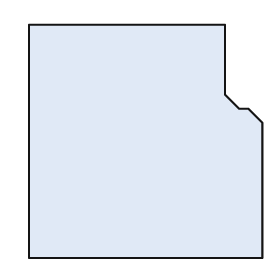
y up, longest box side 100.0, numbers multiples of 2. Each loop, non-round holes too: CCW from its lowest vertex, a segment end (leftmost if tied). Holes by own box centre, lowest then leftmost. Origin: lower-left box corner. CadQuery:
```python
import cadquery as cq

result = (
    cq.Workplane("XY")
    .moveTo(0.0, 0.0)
    .lineTo(100.0, 0.0)
    .lineTo(100.0, 58.0)
    .lineTo(94.0, 64.0)
    .lineTo(90.0, 64.0)
    .lineTo(84.0, 70.0)
    .lineTo(84.0, 100.0)
    .lineTo(0.0, 100.0)
    .close()
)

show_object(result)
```